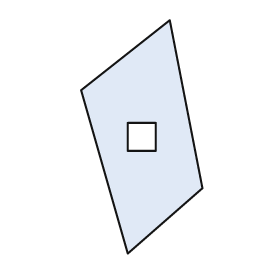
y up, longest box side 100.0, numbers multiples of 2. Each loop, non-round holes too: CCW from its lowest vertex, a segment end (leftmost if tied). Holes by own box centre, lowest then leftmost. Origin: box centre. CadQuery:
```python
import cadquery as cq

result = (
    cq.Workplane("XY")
    .moveTo(-6.0, -50.0)
    .lineTo(26.0, -22.0)
    .lineTo(12.0, 50.0)
    .lineTo(-26.0, 20.0)
    .close()
    .moveTo(-6.0, -6.0)
    .lineTo(6.0, -6.0)
    .lineTo(6.0, 6.0)
    .lineTo(-6.0, 6.0)
    .close()
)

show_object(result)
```